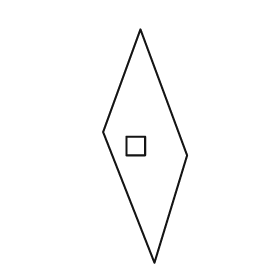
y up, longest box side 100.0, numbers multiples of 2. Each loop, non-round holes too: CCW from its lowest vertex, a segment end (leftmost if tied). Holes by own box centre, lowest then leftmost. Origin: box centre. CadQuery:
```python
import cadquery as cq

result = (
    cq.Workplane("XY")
    .moveTo(4.0, -50.0)
    .lineTo(18.0, -4.0)
    .lineTo(-2.0, 50.0)
    .lineTo(-18.0, 6.0)
    .close()
    .moveTo(-8.0, -4.0)
    .lineTo(0.0, -4.0)
    .lineTo(0.0, 4.0)
    .lineTo(-8.0, 4.0)
    .close()
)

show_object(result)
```